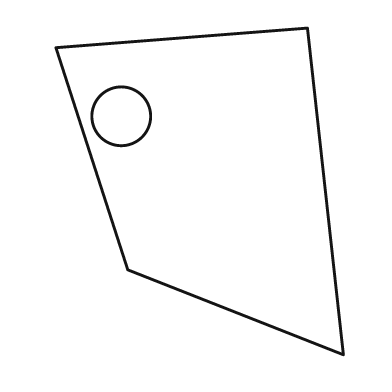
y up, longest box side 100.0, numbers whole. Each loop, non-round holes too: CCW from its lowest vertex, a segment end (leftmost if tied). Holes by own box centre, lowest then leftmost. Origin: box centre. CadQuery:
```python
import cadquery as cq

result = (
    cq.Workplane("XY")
    .moveTo(44.0, -50.0)
    .lineTo(33.0, 50.0)
    .lineTo(-44.0, 44.0)
    .lineTo(-22.0, -24.0)
    .close()
    .moveTo(-24.0, 23.0)
    .circle(9.0)
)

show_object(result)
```